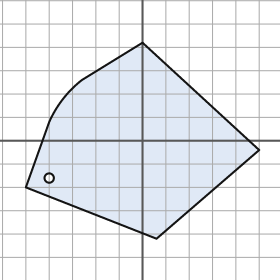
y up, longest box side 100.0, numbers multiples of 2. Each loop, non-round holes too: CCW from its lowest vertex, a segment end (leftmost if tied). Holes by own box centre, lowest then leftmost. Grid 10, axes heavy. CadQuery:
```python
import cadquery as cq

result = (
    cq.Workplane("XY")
    .moveTo(6.0, -42.0)
    .lineTo(50.0, -4.0)
    .lineTo(0.0, 42.0)
    .lineTo(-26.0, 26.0)
    .threePointArc((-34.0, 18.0), (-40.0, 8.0))
    .lineTo(-50.0, -20.0)
    .close()
    .moveTo(-40.0, -16.0)
    .circle(2.0)
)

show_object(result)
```